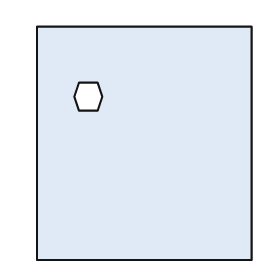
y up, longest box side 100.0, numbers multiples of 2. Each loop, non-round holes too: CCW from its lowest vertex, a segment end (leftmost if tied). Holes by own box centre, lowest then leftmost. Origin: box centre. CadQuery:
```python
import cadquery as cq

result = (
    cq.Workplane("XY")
    .moveTo(-46.0, -50.0)
    .lineTo(46.0, -50.0)
    .lineTo(46.0, 50.0)
    .lineTo(-46.0, 50.0)
    .close()
    .moveTo(-28.0, 14.0)
    .lineTo(-20.0, 14.0)
    .lineTo(-18.0, 20.0)
    .lineTo(-20.0, 26.0)
    .lineTo(-28.0, 26.0)
    .lineTo(-30.0, 20.0)
    .close()
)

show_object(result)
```